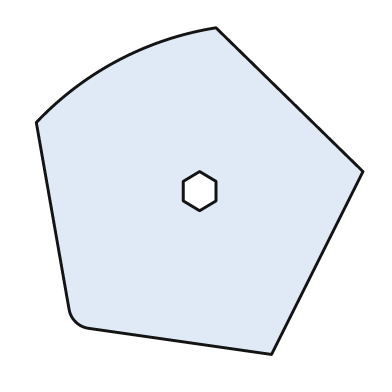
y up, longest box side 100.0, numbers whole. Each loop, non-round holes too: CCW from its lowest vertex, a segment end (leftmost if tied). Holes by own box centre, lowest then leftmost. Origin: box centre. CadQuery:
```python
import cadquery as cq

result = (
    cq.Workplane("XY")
    .moveTo(22.0, -50.0)
    .lineTo(50.0, 6.0)
    .lineTo(5.0, 50.0)
    .threePointArc((-25.0, 40.0), (-50.0, 21.0))
    .lineTo(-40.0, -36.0)
    .threePointArc((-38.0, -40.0), (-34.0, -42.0))
    .close()
    .moveTo(0.0, -6.0)
    .lineTo(5.0, -3.0)
    .lineTo(5.0, 3.0)
    .lineTo(0.0, 6.0)
    .lineTo(-5.0, 3.0)
    .lineTo(-5.0, -3.0)
    .close()
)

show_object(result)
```